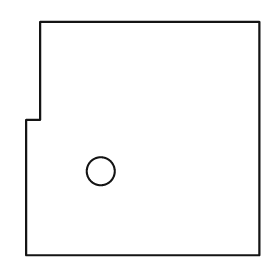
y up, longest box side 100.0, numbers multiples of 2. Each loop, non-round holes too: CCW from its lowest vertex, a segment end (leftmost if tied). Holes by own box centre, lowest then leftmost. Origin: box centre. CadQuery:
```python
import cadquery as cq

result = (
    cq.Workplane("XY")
    .moveTo(-50.0, -50.0)
    .lineTo(50.0, -50.0)
    .lineTo(50.0, 50.0)
    .lineTo(-44.0, 50.0)
    .lineTo(-44.0, 8.0)
    .lineTo(-50.0, 8.0)
    .close()
    .moveTo(-18.0, -14.0)
    .circle(6.0)
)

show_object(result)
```